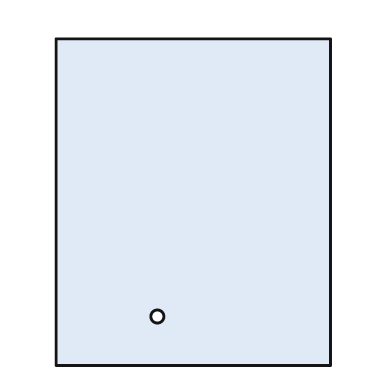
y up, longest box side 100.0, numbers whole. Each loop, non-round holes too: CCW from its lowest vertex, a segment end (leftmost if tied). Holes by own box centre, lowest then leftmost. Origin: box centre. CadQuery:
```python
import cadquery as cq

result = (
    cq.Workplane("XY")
    .moveTo(-42.0, -50.0)
    .lineTo(42.0, -50.0)
    .lineTo(42.0, 50.0)
    .lineTo(-42.0, 50.0)
    .close()
    .moveTo(-11.0, -35.0)
    .circle(2.0)
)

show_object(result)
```